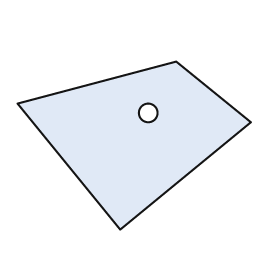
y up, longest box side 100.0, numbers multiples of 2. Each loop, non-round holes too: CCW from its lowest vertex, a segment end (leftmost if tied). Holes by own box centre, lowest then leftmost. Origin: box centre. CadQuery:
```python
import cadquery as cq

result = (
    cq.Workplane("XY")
    .moveTo(-6.0, -36.0)
    .lineTo(50.0, 10.0)
    .lineTo(18.0, 36.0)
    .lineTo(-50.0, 18.0)
    .close()
    .moveTo(6.0, 14.0)
    .circle(4.0)
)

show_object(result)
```